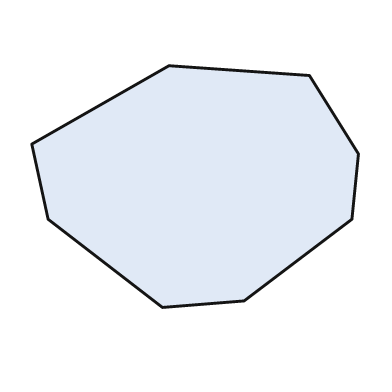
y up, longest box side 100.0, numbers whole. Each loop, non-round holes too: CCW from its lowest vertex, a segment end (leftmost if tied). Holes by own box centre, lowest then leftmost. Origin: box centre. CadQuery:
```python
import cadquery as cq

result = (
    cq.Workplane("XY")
    .moveTo(-10.0, -37.0)
    .lineTo(15.0, -35.0)
    .lineTo(48.0, -10.0)
    .lineTo(50.0, 10.0)
    .lineTo(35.0, 34.0)
    .lineTo(-8.0, 37.0)
    .lineTo(-50.0, 13.0)
    .lineTo(-45.0, -10.0)
    .close()
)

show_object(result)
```